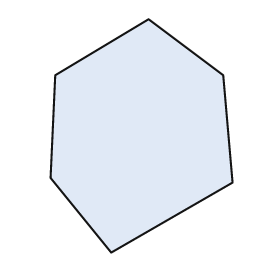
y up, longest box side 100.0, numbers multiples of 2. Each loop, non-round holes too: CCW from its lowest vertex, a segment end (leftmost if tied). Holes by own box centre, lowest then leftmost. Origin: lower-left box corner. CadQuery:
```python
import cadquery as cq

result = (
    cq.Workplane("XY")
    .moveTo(26.0, 0.0)
    .lineTo(78.0, 30.0)
    .lineTo(74.0, 76.0)
    .lineTo(42.0, 100.0)
    .lineTo(2.0, 76.0)
    .lineTo(0.0, 32.0)
    .close()
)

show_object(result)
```